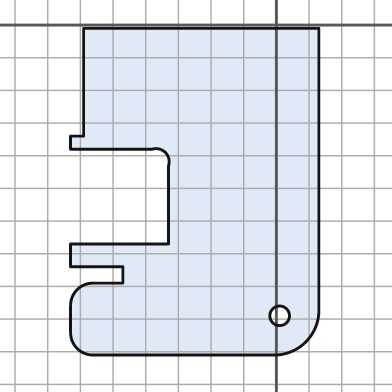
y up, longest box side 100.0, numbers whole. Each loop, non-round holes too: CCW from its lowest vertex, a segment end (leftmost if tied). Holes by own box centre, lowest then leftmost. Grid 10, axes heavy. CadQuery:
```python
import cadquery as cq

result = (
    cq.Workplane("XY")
    .moveTo(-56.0, -101.0)
    .lineTo(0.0, -101.0)
    .threePointArc((9.0, -97.0), (13.0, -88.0))
    .lineTo(13.0, -1.0)
    .lineTo(-59.0, -1.0)
    .lineTo(-59.0, -34.0)
    .lineTo(-63.0, -34.0)
    .lineTo(-63.0, -38.0)
    .lineTo(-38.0, -38.0)
    .threePointArc((-34.0, -39.0), (-33.0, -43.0))
    .lineTo(-33.0, -67.0)
    .lineTo(-63.0, -67.0)
    .lineTo(-63.0, -74.0)
    .lineTo(-47.0, -74.0)
    .lineTo(-47.0, -79.0)
    .lineTo(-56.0, -79.0)
    .threePointArc((-61.0, -81.0), (-63.0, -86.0))
    .lineTo(-63.0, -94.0)
    .threePointArc((-61.0, -99.0), (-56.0, -101.0))
    .close()
    .moveTo(1.0, -89.0)
    .circle(3.0)
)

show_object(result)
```